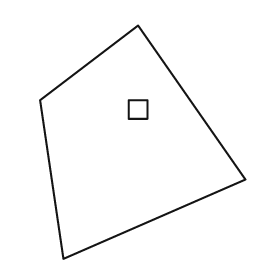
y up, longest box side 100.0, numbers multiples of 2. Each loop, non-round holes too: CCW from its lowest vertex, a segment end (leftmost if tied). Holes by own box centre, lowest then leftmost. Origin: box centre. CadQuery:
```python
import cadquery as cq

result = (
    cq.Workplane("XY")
    .moveTo(-34.0, -50.0)
    .lineTo(44.0, -16.0)
    .lineTo(-2.0, 50.0)
    .lineTo(-44.0, 18.0)
    .close()
    .moveTo(-6.0, 10.0)
    .lineTo(2.0, 10.0)
    .lineTo(2.0, 18.0)
    .lineTo(-6.0, 18.0)
    .close()
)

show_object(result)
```